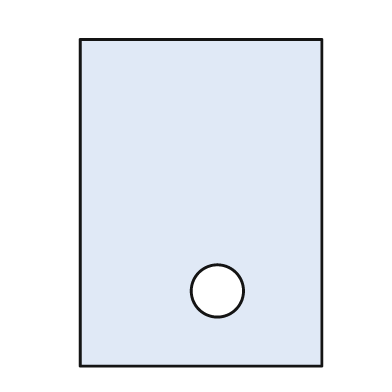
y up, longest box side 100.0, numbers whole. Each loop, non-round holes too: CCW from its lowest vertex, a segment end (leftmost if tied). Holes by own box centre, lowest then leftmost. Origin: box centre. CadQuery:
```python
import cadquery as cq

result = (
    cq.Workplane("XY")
    .moveTo(-37.0, -50.0)
    .lineTo(37.0, -50.0)
    .lineTo(37.0, 50.0)
    .lineTo(-37.0, 50.0)
    .close()
    .moveTo(5.0, -27.0)
    .circle(8.0)
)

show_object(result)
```